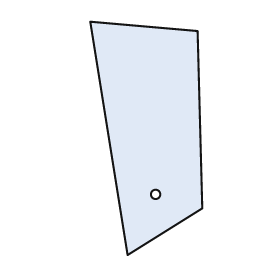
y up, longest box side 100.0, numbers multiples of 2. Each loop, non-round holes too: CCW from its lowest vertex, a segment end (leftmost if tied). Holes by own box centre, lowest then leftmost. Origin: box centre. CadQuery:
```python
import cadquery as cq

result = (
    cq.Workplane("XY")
    .moveTo(-8.0, -50.0)
    .lineTo(24.0, -30.0)
    .lineTo(22.0, 46.0)
    .lineTo(-24.0, 50.0)
    .close()
    .moveTo(4.0, -24.0)
    .circle(2.0)
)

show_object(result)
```